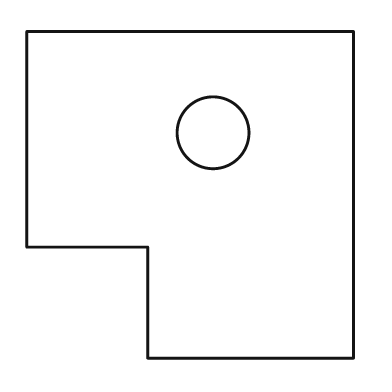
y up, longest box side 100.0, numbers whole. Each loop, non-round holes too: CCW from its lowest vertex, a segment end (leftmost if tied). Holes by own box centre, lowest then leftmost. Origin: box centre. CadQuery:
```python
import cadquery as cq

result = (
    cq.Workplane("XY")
    .moveTo(-13.0, -50.0)
    .lineTo(50.0, -50.0)
    .lineTo(50.0, 50.0)
    .lineTo(-50.0, 50.0)
    .lineTo(-50.0, -16.0)
    .lineTo(-13.0, -16.0)
    .close()
    .moveTo(7.0, 19.0)
    .circle(11.0)
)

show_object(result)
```